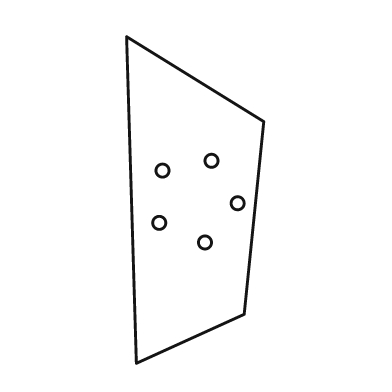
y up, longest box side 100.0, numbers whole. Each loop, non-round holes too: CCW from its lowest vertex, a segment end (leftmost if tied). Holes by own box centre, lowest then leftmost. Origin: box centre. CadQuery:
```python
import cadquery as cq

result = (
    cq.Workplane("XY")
    .moveTo(-18.0, -50.0)
    .lineTo(15.0, -35.0)
    .lineTo(21.0, 24.0)
    .lineTo(-21.0, 50.0)
    .close()
    .moveTo(3.0, -13.0)
    .circle(2.0)
    .moveTo(-11.0, -7.0)
    .circle(2.0)
    .moveTo(13.0, -1.0)
    .circle(2.0)
    .moveTo(-10.0, 9.0)
    .circle(2.0)
    .moveTo(5.0, 12.0)
    .circle(2.0)
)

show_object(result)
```